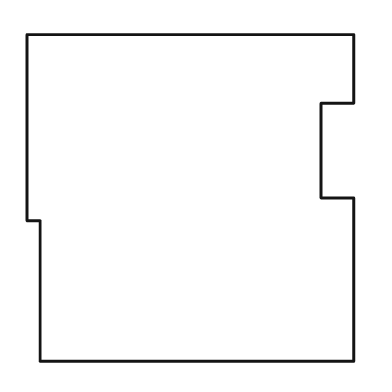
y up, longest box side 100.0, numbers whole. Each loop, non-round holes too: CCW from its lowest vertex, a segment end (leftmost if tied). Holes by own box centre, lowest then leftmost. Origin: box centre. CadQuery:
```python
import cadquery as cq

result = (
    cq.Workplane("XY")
    .moveTo(-46.0, -50.0)
    .lineTo(50.0, -50.0)
    .lineTo(50.0, 0.0)
    .lineTo(40.0, 0.0)
    .lineTo(40.0, 29.0)
    .lineTo(50.0, 29.0)
    .lineTo(50.0, 50.0)
    .lineTo(-50.0, 50.0)
    .lineTo(-50.0, -7.0)
    .lineTo(-46.0, -7.0)
    .close()
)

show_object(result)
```